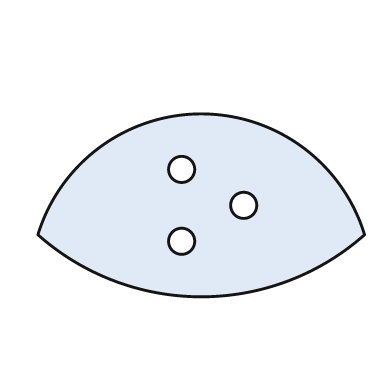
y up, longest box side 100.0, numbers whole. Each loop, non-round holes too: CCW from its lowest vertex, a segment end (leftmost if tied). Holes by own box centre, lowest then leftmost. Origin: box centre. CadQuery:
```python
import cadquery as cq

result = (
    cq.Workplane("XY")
    .moveTo(-50.0, -9.0)
    .threePointArc((0.0, -28.0), (50.0, -9.0))
    .threePointArc((0.0, 28.0), (-50.0, -9.0))
    .close()
    .moveTo(-6.0, -11.0)
    .circle(4.0)
    .moveTo(13.0, 0.0)
    .circle(4.0)
    .moveTo(-6.0, 11.0)
    .circle(4.0)
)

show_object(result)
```